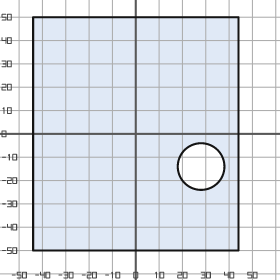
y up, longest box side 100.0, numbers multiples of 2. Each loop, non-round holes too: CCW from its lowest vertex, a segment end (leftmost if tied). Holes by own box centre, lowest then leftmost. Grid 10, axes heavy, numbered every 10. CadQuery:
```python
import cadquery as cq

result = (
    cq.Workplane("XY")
    .moveTo(-44.0, -50.0)
    .lineTo(44.0, -50.0)
    .lineTo(44.0, 50.0)
    .lineTo(-44.0, 50.0)
    .close()
    .moveTo(28.0, -14.0)
    .circle(10.0)
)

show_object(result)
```